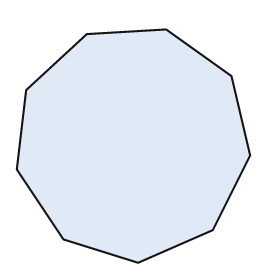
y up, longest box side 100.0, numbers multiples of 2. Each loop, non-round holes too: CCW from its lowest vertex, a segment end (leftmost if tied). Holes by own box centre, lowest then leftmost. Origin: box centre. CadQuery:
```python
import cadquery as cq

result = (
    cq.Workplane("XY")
    .moveTo(2.0, -50.0)
    .lineTo(34.0, -36.0)
    .lineTo(50.0, -4.0)
    .lineTo(42.0, 30.0)
    .lineTo(14.0, 50.0)
    .lineTo(-20.0, 48.0)
    .lineTo(-46.0, 24.0)
    .lineTo(-50.0, -10.0)
    .lineTo(-30.0, -40.0)
    .close()
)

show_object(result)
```